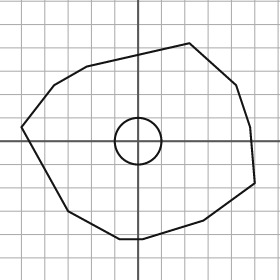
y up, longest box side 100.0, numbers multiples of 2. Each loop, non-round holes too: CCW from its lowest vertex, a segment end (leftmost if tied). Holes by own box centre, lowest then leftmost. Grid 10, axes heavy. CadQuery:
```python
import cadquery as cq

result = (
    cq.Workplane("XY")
    .moveTo(-8.0, -42.0)
    .lineTo(2.0, -42.0)
    .lineTo(28.0, -34.0)
    .lineTo(50.0, -18.0)
    .lineTo(48.0, 6.0)
    .lineTo(42.0, 24.0)
    .lineTo(22.0, 42.0)
    .lineTo(-22.0, 32.0)
    .lineTo(-36.0, 24.0)
    .lineTo(-50.0, 6.0)
    .lineTo(-30.0, -30.0)
    .close()
    .moveTo(0.0, 0.0)
    .circle(10.0)
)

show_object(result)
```